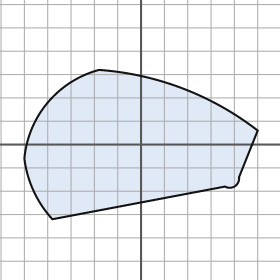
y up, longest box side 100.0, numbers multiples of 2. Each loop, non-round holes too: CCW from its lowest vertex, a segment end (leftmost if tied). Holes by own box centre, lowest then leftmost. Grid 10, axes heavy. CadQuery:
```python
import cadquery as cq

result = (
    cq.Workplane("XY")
    .moveTo(-38.0, -32.0)
    .lineTo(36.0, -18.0)
    .threePointArc((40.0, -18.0), (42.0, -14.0))
    .lineTo(50.0, 6.0)
    .threePointArc((18.0, 24.0), (-18.0, 32.0))
    .threePointArc((-40.0, 18.0), (-50.0, -6.0))
    .threePointArc((-46.0, -20.0), (-38.0, -32.0))
    .close()
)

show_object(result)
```